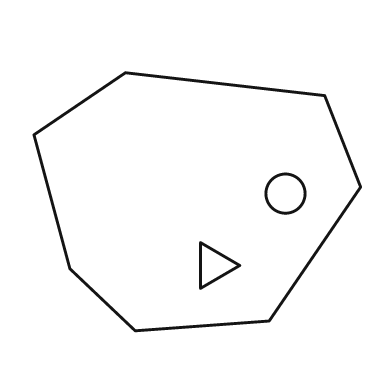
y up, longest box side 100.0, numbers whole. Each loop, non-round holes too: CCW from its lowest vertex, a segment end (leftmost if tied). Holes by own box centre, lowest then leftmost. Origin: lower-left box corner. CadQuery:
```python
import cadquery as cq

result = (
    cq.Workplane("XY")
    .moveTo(31.0, 0.0)
    .lineTo(72.0, 3.0)
    .lineTo(100.0, 44.0)
    .lineTo(89.0, 72.0)
    .lineTo(28.0, 79.0)
    .lineTo(0.0, 60.0)
    .lineTo(11.0, 19.0)
    .close()
    .moveTo(51.0, 13.0)
    .lineTo(63.0, 20.0)
    .lineTo(51.0, 27.0)
    .close()
    .moveTo(77.0, 42.0)
    .circle(6.0)
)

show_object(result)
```